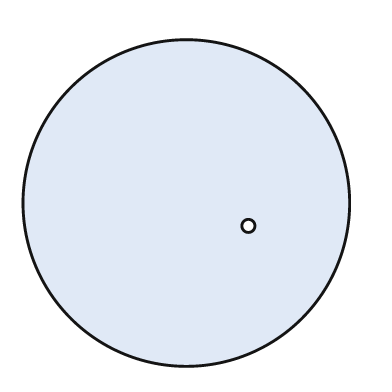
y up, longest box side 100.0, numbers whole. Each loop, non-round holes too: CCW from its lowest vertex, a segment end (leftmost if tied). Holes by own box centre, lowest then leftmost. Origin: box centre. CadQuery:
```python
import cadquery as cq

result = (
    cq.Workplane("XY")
    .moveTo(0.0, 0.0)
    .circle(50.0)
    .moveTo(19.0, -7.0)
    .circle(2.0)
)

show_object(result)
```